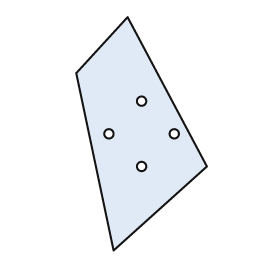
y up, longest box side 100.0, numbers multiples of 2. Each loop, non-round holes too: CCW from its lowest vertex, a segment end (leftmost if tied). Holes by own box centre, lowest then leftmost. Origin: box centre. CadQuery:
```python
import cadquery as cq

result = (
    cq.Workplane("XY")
    .moveTo(-12.0, -50.0)
    .lineTo(28.0, -14.0)
    .lineTo(-6.0, 50.0)
    .lineTo(-28.0, 26.0)
    .close()
    .moveTo(0.0, -14.0)
    .circle(2.0)
    .moveTo(-14.0, 0.0)
    .circle(2.0)
    .moveTo(14.0, 0.0)
    .circle(2.0)
    .moveTo(0.0, 14.0)
    .circle(2.0)
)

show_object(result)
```